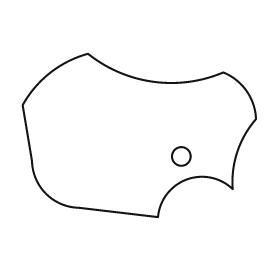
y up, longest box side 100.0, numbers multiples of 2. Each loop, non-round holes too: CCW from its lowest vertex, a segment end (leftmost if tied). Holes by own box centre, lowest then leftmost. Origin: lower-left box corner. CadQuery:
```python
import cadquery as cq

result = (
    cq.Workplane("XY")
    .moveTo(58.0, 0.0)
    .threePointArc((70.0, 16.0), (90.0, 12.0))
    .threePointArc((92.0, 28.0), (100.0, 42.0))
    .threePointArc((96.0, 54.0), (86.0, 62.0))
    .threePointArc((56.0, 58.0), (28.0, 70.0))
    .threePointArc((12.0, 62.0), (0.0, 48.0))
    .lineTo(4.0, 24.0)
    .threePointArc((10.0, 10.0), (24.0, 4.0))
    .close()
    .moveTo(68.0, 26.0)
    .circle(4.0)
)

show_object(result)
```